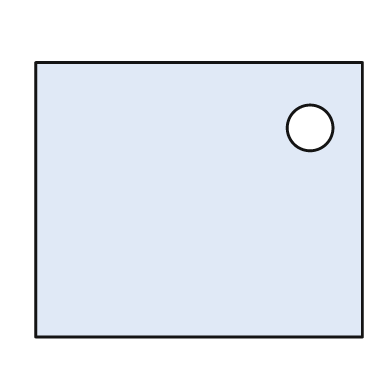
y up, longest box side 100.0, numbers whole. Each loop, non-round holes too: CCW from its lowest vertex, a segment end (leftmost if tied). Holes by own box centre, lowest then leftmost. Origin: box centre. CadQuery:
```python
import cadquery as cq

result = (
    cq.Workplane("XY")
    .moveTo(-50.0, -42.0)
    .lineTo(50.0, -42.0)
    .lineTo(50.0, 42.0)
    .lineTo(-50.0, 42.0)
    .close()
    .moveTo(34.0, 22.0)
    .circle(7.0)
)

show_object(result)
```